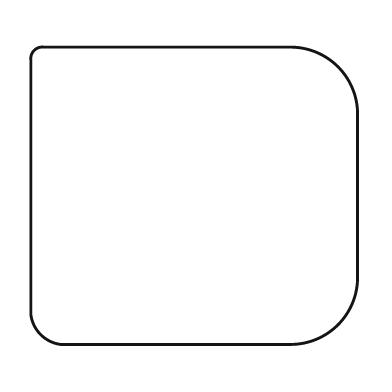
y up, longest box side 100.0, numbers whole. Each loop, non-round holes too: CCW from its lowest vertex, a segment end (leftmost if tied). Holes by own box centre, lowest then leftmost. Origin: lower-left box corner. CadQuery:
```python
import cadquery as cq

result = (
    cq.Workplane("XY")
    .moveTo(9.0, 0.0)
    .lineTo(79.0, 0.0)
    .threePointArc((94.0, 6.0), (100.0, 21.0))
    .lineTo(100.0, 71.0)
    .threePointArc((94.0, 85.0), (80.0, 91.0))
    .lineTo(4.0, 91.0)
    .threePointArc((1.0, 90.0), (0.0, 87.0))
    .lineTo(0.0, 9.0)
    .threePointArc((3.0, 3.0), (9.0, 0.0))
    .close()
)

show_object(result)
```